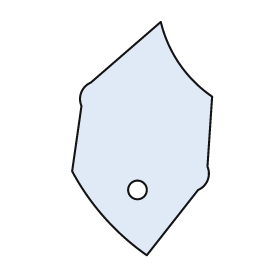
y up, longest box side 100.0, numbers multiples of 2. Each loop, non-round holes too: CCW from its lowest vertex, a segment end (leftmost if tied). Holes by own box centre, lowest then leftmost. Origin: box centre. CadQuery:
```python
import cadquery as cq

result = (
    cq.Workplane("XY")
    .moveTo(2.0, -50.0)
    .lineTo(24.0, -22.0)
    .threePointArc((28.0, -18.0), (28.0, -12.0))
    .lineTo(30.0, 18.0)
    .threePointArc((16.0, 32.0), (8.0, 50.0))
    .lineTo(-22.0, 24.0)
    .threePointArc((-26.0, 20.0), (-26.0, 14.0))
    .lineTo(-30.0, -14.0)
    .threePointArc((-16.0, -34.0), (2.0, -50.0))
    .close()
    .moveTo(-2.0, -22.0)
    .circle(4.0)
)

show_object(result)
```